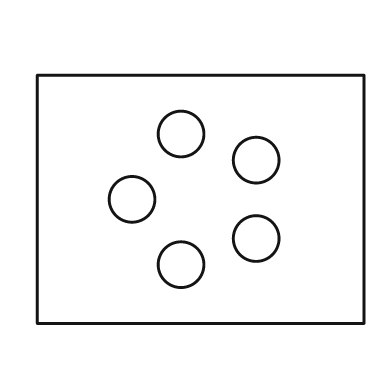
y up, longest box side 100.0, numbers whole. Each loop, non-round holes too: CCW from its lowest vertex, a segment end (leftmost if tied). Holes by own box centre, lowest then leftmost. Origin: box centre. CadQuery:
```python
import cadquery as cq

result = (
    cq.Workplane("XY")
    .moveTo(-50.0, -38.0)
    .lineTo(50.0, -38.0)
    .lineTo(50.0, 38.0)
    .lineTo(-50.0, 38.0)
    .close()
    .moveTo(-6.0, -20.0)
    .circle(7.0)
    .moveTo(17.0, -12.0)
    .circle(7.0)
    .moveTo(-21.0, 0.0)
    .circle(7.0)
    .moveTo(17.0, 12.0)
    .circle(7.0)
    .moveTo(-6.0, 20.0)
    .circle(7.0)
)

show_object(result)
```